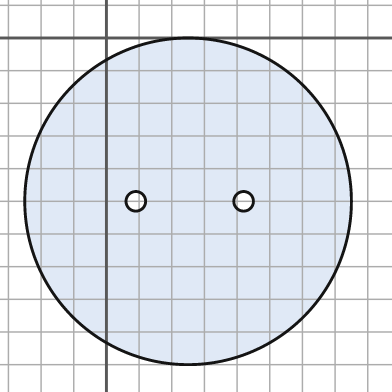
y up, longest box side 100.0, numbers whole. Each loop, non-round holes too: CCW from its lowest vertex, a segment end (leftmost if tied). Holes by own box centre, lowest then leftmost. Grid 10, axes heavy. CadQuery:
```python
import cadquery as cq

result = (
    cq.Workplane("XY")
    .moveTo(25.0, -50.0)
    .circle(50.0)
    .moveTo(9.0, -50.0)
    .circle(3.0)
    .moveTo(42.0, -50.0)
    .circle(3.0)
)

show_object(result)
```